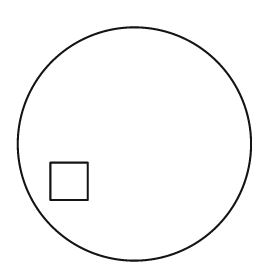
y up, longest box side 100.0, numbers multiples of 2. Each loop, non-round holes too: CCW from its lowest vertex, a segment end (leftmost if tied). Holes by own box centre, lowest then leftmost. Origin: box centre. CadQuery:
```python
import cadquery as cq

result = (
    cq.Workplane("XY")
    .moveTo(0.0, 0.0)
    .circle(50.0)
    .moveTo(-36.0, -24.0)
    .lineTo(-20.0, -24.0)
    .lineTo(-20.0, -8.0)
    .lineTo(-36.0, -8.0)
    .close()
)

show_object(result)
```